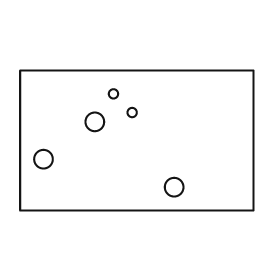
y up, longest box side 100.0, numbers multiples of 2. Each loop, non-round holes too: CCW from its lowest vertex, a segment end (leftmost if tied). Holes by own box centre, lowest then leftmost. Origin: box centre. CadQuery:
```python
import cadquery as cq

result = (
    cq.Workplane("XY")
    .moveTo(-50.0, -30.0)
    .lineTo(50.0, -30.0)
    .lineTo(50.0, 30.0)
    .lineTo(-50.0, 30.0)
    .close()
    .moveTo(16.0, -20.0)
    .circle(4.0)
    .moveTo(-40.0, -8.0)
    .circle(4.0)
    .moveTo(-18.0, 8.0)
    .circle(4.0)
    .moveTo(-2.0, 12.0)
    .circle(2.0)
    .moveTo(-10.0, 20.0)
    .circle(2.0)
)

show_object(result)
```